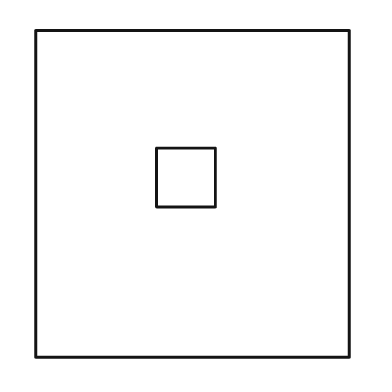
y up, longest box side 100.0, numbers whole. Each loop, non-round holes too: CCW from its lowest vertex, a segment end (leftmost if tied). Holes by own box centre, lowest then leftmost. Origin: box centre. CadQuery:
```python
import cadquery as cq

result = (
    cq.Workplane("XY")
    .moveTo(-48.0, -50.0)
    .lineTo(48.0, -50.0)
    .lineTo(48.0, 50.0)
    .lineTo(-48.0, 50.0)
    .close()
    .moveTo(-11.0, -4.0)
    .lineTo(7.0, -4.0)
    .lineTo(7.0, 14.0)
    .lineTo(-11.0, 14.0)
    .close()
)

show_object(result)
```